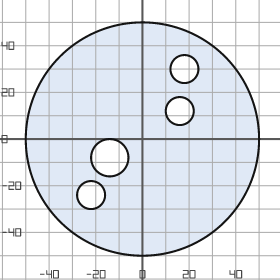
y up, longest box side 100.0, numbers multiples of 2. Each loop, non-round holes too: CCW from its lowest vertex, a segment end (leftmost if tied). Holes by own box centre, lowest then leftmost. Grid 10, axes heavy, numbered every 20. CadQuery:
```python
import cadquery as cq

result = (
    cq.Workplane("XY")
    .moveTo(0.0, 0.0)
    .circle(50.0)
    .moveTo(-22.0, -24.0)
    .circle(6.0)
    .moveTo(-14.0, -8.0)
    .circle(8.0)
    .moveTo(16.0, 12.0)
    .circle(6.0)
    .moveTo(18.0, 30.0)
    .circle(6.0)
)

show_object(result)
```